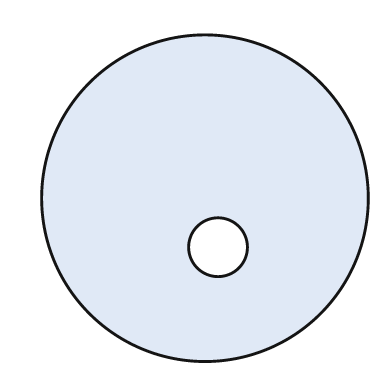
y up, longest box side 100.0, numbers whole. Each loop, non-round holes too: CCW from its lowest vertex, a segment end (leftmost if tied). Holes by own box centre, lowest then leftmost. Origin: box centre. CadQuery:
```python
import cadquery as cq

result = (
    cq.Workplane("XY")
    .moveTo(0.0, 0.0)
    .circle(50.0)
    .moveTo(4.0, -15.0)
    .circle(9.0)
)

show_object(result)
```